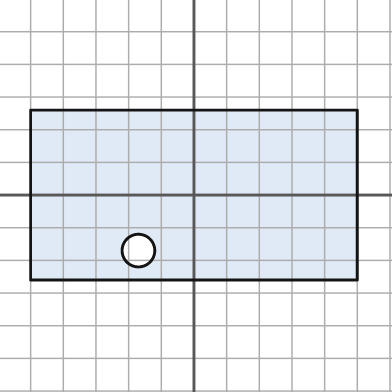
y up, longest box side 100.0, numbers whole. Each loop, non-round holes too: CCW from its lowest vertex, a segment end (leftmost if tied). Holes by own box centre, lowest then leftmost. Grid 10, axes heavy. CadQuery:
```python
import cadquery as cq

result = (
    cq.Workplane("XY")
    .moveTo(-50.0, -26.0)
    .lineTo(50.0, -26.0)
    .lineTo(50.0, 26.0)
    .lineTo(-50.0, 26.0)
    .close()
    .moveTo(-17.0, -17.0)
    .circle(5.0)
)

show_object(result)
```